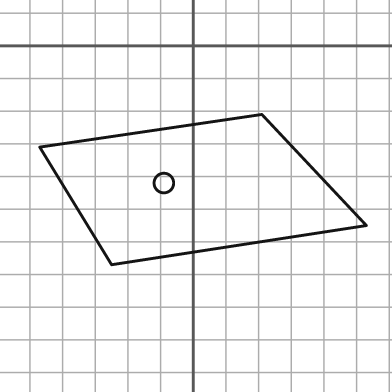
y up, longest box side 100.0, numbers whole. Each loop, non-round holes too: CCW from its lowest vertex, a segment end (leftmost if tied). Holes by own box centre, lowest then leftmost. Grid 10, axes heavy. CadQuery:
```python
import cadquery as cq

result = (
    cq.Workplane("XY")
    .moveTo(-25.0, -67.0)
    .lineTo(53.0, -55.0)
    .lineTo(21.0, -21.0)
    .lineTo(-47.0, -31.0)
    .close()
    .moveTo(-9.0, -42.0)
    .circle(3.0)
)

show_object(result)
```